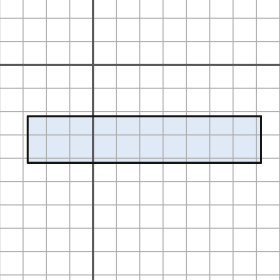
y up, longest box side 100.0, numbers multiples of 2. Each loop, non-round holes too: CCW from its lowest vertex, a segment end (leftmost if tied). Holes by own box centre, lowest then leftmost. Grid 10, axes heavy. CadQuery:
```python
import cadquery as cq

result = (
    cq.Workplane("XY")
    .moveTo(-28.0, -42.0)
    .lineTo(72.0, -42.0)
    .lineTo(72.0, -22.0)
    .lineTo(-28.0, -22.0)
    .close()
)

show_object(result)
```